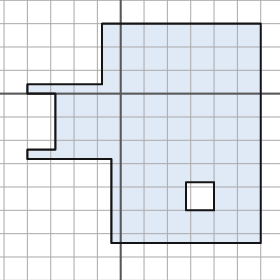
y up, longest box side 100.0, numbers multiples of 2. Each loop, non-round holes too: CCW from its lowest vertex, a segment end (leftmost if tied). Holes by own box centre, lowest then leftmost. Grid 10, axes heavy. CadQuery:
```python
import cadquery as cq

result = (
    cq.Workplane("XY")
    .moveTo(-4.0, -64.0)
    .lineTo(60.0, -64.0)
    .lineTo(60.0, 30.0)
    .lineTo(-8.0, 30.0)
    .lineTo(-8.0, 4.0)
    .lineTo(-40.0, 4.0)
    .lineTo(-40.0, 0.0)
    .lineTo(-28.0, 0.0)
    .lineTo(-28.0, -24.0)
    .lineTo(-40.0, -24.0)
    .lineTo(-40.0, -28.0)
    .lineTo(-4.0, -28.0)
    .close()
    .moveTo(28.0, -50.0)
    .lineTo(40.0, -50.0)
    .lineTo(40.0, -38.0)
    .lineTo(28.0, -38.0)
    .close()
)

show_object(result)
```